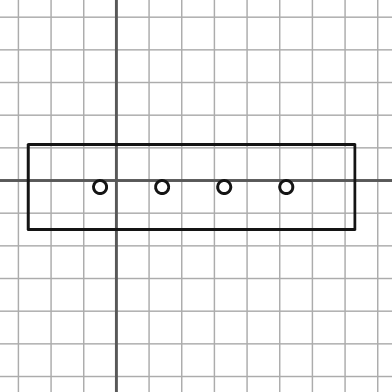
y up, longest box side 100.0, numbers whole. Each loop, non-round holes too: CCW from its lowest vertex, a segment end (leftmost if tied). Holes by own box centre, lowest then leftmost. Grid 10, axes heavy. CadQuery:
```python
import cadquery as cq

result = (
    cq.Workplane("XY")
    .moveTo(-27.0, -15.0)
    .lineTo(73.0, -15.0)
    .lineTo(73.0, 11.0)
    .lineTo(-27.0, 11.0)
    .close()
    .moveTo(-5.0, -2.0)
    .circle(2.0)
    .moveTo(14.0, -2.0)
    .circle(2.0)
    .moveTo(33.0, -2.0)
    .circle(2.0)
    .moveTo(52.0, -2.0)
    .circle(2.0)
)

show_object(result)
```